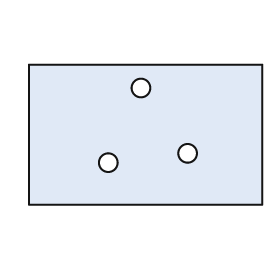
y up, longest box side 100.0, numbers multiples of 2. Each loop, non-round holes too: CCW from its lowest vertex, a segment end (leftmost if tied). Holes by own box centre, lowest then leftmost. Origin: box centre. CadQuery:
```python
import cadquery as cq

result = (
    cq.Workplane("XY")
    .moveTo(-50.0, -30.0)
    .lineTo(50.0, -30.0)
    .lineTo(50.0, 30.0)
    .lineTo(-50.0, 30.0)
    .close()
    .moveTo(-16.0, -12.0)
    .circle(4.0)
    .moveTo(18.0, -8.0)
    .circle(4.0)
    .moveTo(-2.0, 20.0)
    .circle(4.0)
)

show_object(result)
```